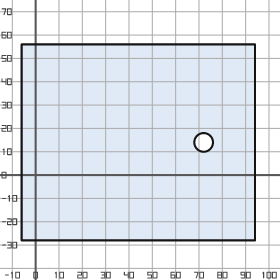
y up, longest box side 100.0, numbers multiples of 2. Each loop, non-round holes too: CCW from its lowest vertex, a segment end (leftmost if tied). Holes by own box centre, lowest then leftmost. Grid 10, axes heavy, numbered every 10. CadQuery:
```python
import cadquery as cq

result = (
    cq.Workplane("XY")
    .moveTo(-6.0, -28.0)
    .lineTo(94.0, -28.0)
    .lineTo(94.0, 56.0)
    .lineTo(-6.0, 56.0)
    .close()
    .moveTo(72.0, 14.0)
    .circle(4.0)
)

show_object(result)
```